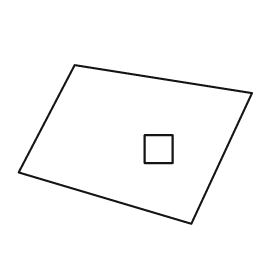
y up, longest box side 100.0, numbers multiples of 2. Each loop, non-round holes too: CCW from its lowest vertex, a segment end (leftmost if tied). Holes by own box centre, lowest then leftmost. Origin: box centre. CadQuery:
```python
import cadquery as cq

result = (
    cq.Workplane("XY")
    .moveTo(24.0, -34.0)
    .lineTo(50.0, 22.0)
    .lineTo(-26.0, 34.0)
    .lineTo(-50.0, -12.0)
    .close()
    .moveTo(4.0, -8.0)
    .lineTo(16.0, -8.0)
    .lineTo(16.0, 4.0)
    .lineTo(4.0, 4.0)
    .close()
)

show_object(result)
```